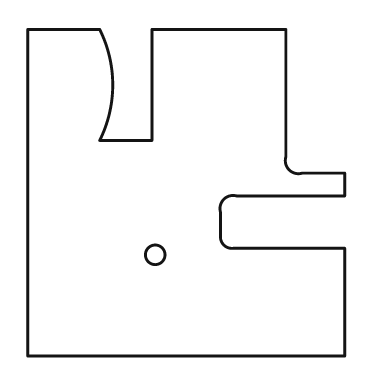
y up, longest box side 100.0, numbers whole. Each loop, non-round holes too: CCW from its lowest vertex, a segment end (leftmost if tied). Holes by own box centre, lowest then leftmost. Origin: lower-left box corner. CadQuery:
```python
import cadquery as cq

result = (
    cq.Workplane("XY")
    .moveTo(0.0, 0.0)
    .lineTo(97.0, 0.0)
    .lineTo(97.0, 33.0)
    .lineTo(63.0, 33.0)
    .threePointArc((60.0, 34.0), (59.0, 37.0))
    .lineTo(59.0, 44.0)
    .threePointArc((60.0, 48.0), (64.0, 49.0))
    .lineTo(97.0, 49.0)
    .lineTo(97.0, 56.0)
    .lineTo(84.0, 56.0)
    .threePointArc((80.0, 57.0), (79.0, 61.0))
    .lineTo(79.0, 100.0)
    .lineTo(38.0, 100.0)
    .lineTo(38.0, 66.0)
    .lineTo(22.0, 66.0)
    .threePointArc((26.0, 83.0), (22.0, 100.0))
    .lineTo(0.0, 100.0)
    .close()
    .moveTo(39.0, 31.0)
    .circle(3.0)
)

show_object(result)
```